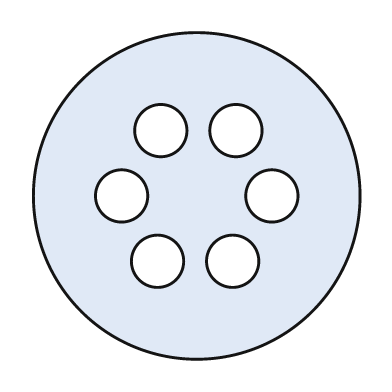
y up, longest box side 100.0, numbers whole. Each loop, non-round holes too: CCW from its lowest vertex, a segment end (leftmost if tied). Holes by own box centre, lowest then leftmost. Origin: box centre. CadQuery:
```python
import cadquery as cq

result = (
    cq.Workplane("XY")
    .moveTo(0.0, 0.0)
    .circle(50.0)
    .moveTo(-12.0, -20.0)
    .circle(8.0)
    .moveTo(11.0, -20.0)
    .circle(8.0)
    .moveTo(-23.0, 0.0)
    .circle(8.0)
    .moveTo(23.0, 0.0)
    .circle(8.0)
    .moveTo(-11.0, 20.0)
    .circle(8.0)
    .moveTo(12.0, 20.0)
    .circle(8.0)
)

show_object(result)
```